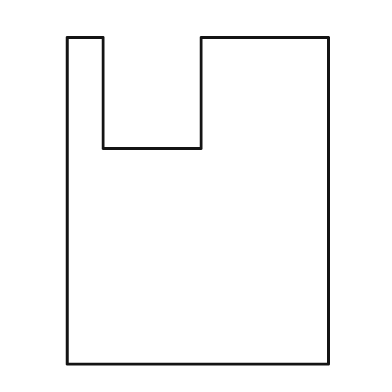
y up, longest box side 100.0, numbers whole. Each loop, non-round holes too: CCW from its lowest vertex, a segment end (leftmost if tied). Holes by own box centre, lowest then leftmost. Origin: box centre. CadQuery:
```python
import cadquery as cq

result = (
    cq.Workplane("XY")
    .moveTo(-40.0, -50.0)
    .lineTo(40.0, -50.0)
    .lineTo(40.0, 50.0)
    .lineTo(1.0, 50.0)
    .lineTo(1.0, 16.0)
    .lineTo(-29.0, 16.0)
    .lineTo(-29.0, 50.0)
    .lineTo(-40.0, 50.0)
    .close()
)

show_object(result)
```